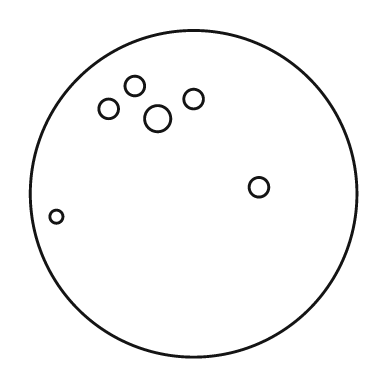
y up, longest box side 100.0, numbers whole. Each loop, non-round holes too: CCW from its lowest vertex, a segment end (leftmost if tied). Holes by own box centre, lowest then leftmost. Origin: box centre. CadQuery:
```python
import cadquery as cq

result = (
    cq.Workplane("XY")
    .moveTo(0.0, 0.0)
    .circle(50.0)
    .moveTo(-42.0, -7.0)
    .circle(2.0)
    .moveTo(20.0, 2.0)
    .circle(3.0)
    .moveTo(-11.0, 23.0)
    .circle(4.0)
    .moveTo(-26.0, 26.0)
    .circle(3.0)
    .moveTo(0.0, 29.0)
    .circle(3.0)
    .moveTo(-18.0, 33.0)
    .circle(3.0)
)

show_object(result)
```